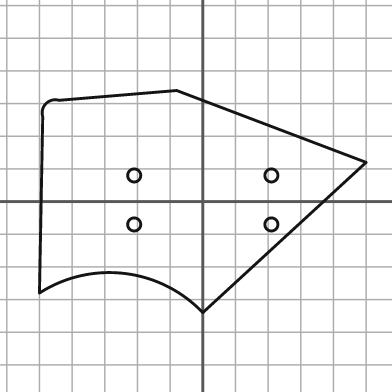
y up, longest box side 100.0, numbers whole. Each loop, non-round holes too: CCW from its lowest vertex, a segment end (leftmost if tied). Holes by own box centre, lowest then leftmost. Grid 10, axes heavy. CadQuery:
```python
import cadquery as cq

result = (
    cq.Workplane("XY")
    .moveTo(0.0, -34.0)
    .lineTo(50.0, 12.0)
    .lineTo(-8.0, 34.0)
    .lineTo(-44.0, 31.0)
    .threePointArc((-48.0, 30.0), (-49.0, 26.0))
    .lineTo(-50.0, -28.0)
    .threePointArc((-24.0, -22.0), (0.0, -34.0))
    .close()
    .moveTo(-21.0, -7.0)
    .circle(2.0)
    .moveTo(21.0, -7.0)
    .circle(2.0)
    .moveTo(-21.0, 8.0)
    .circle(2.0)
    .moveTo(21.0, 8.0)
    .circle(2.0)
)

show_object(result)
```